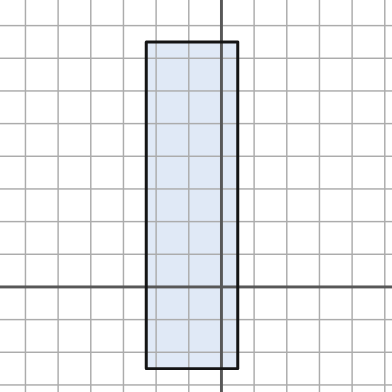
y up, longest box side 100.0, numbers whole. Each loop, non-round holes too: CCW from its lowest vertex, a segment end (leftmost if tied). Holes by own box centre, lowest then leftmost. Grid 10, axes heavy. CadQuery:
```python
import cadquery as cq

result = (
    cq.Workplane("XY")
    .moveTo(-23.0, -25.0)
    .lineTo(5.0, -25.0)
    .lineTo(5.0, 75.0)
    .lineTo(-23.0, 75.0)
    .close()
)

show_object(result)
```